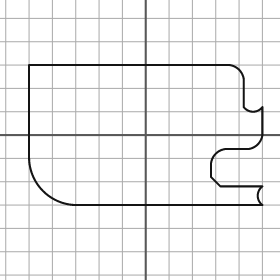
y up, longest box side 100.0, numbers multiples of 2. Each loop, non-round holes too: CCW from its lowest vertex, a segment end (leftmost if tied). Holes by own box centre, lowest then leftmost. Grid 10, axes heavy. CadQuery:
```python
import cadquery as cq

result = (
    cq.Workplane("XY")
    .moveTo(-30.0, -30.0)
    .lineTo(50.0, -30.0)
    .threePointArc((48.0, -26.0), (50.0, -22.0))
    .lineTo(32.0, -22.0)
    .lineTo(28.0, -18.0)
    .lineTo(28.0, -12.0)
    .threePointArc((30.0, -8.0), (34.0, -6.0))
    .lineTo(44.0, -6.0)
    .threePointArc((48.0, -4.0), (50.0, 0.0))
    .lineTo(50.0, 12.0)
    .threePointArc((46.0, 10.0), (42.0, 12.0))
    .lineTo(42.0, 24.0)
    .threePointArc((40.0, 28.0), (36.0, 30.0))
    .lineTo(-50.0, 30.0)
    .lineTo(-50.0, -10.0)
    .threePointArc((-44.0, -24.0), (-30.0, -30.0))
    .close()
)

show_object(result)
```